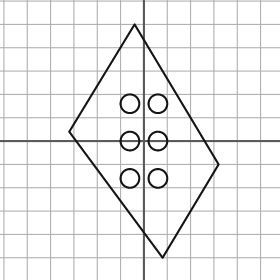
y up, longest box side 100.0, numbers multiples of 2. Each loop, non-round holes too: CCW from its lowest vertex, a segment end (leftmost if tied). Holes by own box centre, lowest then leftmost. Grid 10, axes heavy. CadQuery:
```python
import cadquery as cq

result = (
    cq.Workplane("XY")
    .moveTo(8.0, -50.0)
    .lineTo(32.0, -10.0)
    .lineTo(-4.0, 50.0)
    .lineTo(-32.0, 4.0)
    .close()
    .moveTo(-6.0, -16.0)
    .circle(4.0)
    .moveTo(6.0, -16.0)
    .circle(4.0)
    .moveTo(-6.0, 0.0)
    .circle(4.0)
    .moveTo(6.0, 0.0)
    .circle(4.0)
    .moveTo(-6.0, 16.0)
    .circle(4.0)
    .moveTo(6.0, 16.0)
    .circle(4.0)
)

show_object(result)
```